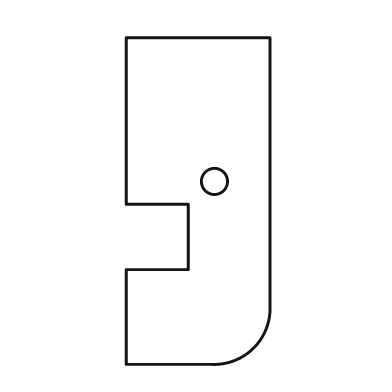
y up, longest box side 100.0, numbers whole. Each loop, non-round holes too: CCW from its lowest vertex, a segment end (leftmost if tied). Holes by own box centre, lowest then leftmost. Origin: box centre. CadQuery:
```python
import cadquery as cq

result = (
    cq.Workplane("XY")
    .moveTo(-22.0, -50.0)
    .lineTo(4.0, -50.0)
    .threePointArc((17.0, -45.0), (22.0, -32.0))
    .lineTo(22.0, 50.0)
    .lineTo(-22.0, 50.0)
    .lineTo(-22.0, -1.0)
    .lineTo(-3.0, -1.0)
    .lineTo(-3.0, -21.0)
    .lineTo(-22.0, -21.0)
    .close()
    .moveTo(5.0, 6.0)
    .circle(4.0)
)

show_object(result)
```